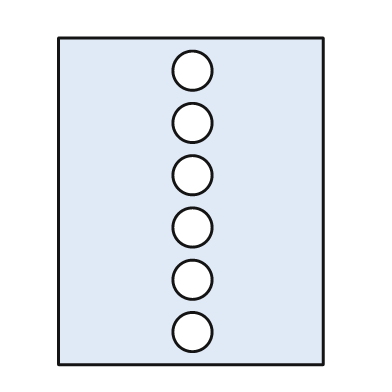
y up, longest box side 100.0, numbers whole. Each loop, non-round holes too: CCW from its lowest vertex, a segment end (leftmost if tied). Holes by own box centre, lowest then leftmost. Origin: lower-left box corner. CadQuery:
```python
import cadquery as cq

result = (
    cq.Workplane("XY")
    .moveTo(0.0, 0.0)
    .lineTo(81.0, 0.0)
    .lineTo(81.0, 100.0)
    .lineTo(0.0, 100.0)
    .close()
    .moveTo(41.0, 10.0)
    .circle(6.0)
    .moveTo(41.0, 26.0)
    .circle(6.0)
    .moveTo(41.0, 42.0)
    .circle(6.0)
    .moveTo(41.0, 58.0)
    .circle(6.0)
    .moveTo(41.0, 74.0)
    .circle(6.0)
    .moveTo(41.0, 90.0)
    .circle(6.0)
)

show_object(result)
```